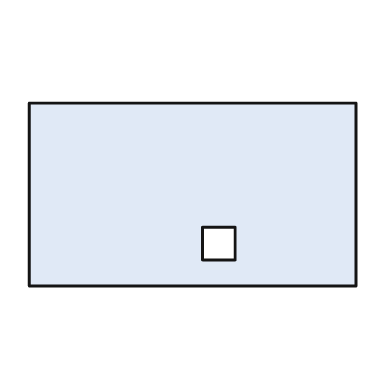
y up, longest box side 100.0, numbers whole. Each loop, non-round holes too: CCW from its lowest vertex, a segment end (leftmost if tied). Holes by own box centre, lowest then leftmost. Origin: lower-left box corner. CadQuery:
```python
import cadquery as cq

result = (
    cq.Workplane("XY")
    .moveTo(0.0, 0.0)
    .lineTo(100.0, 0.0)
    .lineTo(100.0, 56.0)
    .lineTo(0.0, 56.0)
    .close()
    .moveTo(53.0, 8.0)
    .lineTo(63.0, 8.0)
    .lineTo(63.0, 18.0)
    .lineTo(53.0, 18.0)
    .close()
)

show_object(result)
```